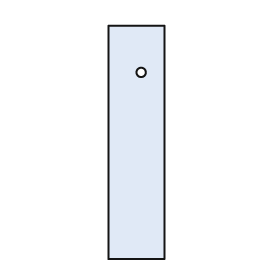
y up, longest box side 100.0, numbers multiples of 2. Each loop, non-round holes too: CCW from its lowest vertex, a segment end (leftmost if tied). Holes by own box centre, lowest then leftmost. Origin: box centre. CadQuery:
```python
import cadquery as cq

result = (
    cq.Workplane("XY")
    .moveTo(-12.0, -50.0)
    .lineTo(12.0, -50.0)
    .lineTo(12.0, 50.0)
    .lineTo(-12.0, 50.0)
    .close()
    .moveTo(2.0, 30.0)
    .circle(2.0)
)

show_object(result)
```